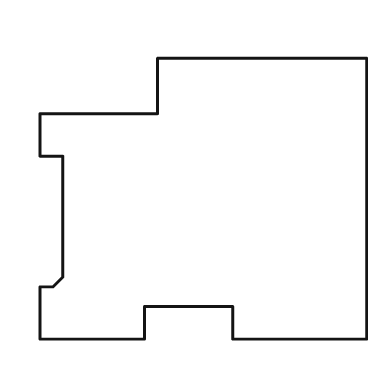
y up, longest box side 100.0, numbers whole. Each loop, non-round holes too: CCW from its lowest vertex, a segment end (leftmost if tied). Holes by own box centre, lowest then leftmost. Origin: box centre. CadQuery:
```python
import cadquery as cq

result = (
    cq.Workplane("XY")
    .moveTo(-50.0, -43.0)
    .lineTo(-18.0, -43.0)
    .lineTo(-18.0, -33.0)
    .lineTo(9.0, -33.0)
    .lineTo(9.0, -43.0)
    .lineTo(50.0, -43.0)
    .lineTo(50.0, 43.0)
    .lineTo(-14.0, 43.0)
    .lineTo(-14.0, 26.0)
    .lineTo(-50.0, 26.0)
    .lineTo(-50.0, 13.0)
    .lineTo(-43.0, 13.0)
    .lineTo(-43.0, -24.0)
    .lineTo(-46.0, -27.0)
    .lineTo(-50.0, -27.0)
    .close()
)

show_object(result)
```